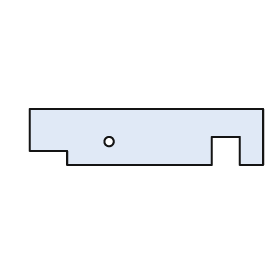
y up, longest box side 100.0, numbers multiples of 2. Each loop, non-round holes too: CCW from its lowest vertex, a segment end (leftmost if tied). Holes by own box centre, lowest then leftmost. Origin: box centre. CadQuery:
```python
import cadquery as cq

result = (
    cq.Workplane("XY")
    .moveTo(-34.0, -12.0)
    .lineTo(28.0, -12.0)
    .lineTo(28.0, 0.0)
    .lineTo(40.0, 0.0)
    .lineTo(40.0, -12.0)
    .lineTo(50.0, -12.0)
    .lineTo(50.0, 12.0)
    .lineTo(-50.0, 12.0)
    .lineTo(-50.0, -6.0)
    .lineTo(-34.0, -6.0)
    .close()
    .moveTo(-16.0, -2.0)
    .circle(2.0)
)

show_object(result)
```